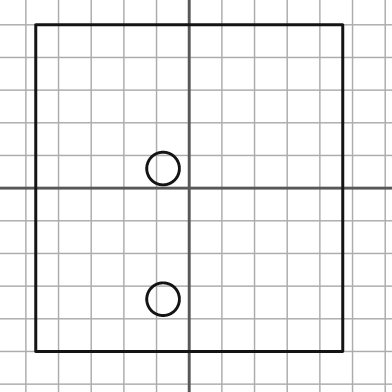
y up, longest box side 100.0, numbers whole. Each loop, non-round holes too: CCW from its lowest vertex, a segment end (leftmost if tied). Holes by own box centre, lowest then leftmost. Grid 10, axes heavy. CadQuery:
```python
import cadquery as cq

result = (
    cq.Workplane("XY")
    .moveTo(-47.0, -50.0)
    .lineTo(47.0, -50.0)
    .lineTo(47.0, 50.0)
    .lineTo(-47.0, 50.0)
    .close()
    .moveTo(-8.0, -34.0)
    .circle(5.0)
    .moveTo(-8.0, 6.0)
    .circle(5.0)
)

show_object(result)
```